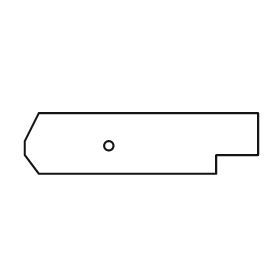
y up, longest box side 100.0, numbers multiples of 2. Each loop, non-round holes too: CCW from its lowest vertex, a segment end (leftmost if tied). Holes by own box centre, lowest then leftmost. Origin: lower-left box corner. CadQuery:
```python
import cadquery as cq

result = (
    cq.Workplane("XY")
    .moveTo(6.0, 0.0)
    .lineTo(82.0, 0.0)
    .lineTo(82.0, 8.0)
    .lineTo(100.0, 8.0)
    .lineTo(100.0, 26.0)
    .lineTo(6.0, 26.0)
    .lineTo(0.0, 14.0)
    .lineTo(0.0, 8.0)
    .close()
    .moveTo(36.0, 12.0)
    .circle(2.0)
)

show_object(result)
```